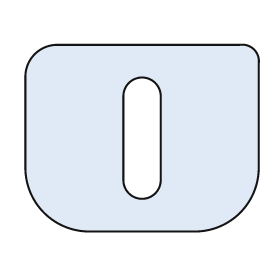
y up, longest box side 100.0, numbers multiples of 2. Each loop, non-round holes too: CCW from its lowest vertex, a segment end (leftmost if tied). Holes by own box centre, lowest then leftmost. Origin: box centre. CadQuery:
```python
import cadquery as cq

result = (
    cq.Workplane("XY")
    .moveTo(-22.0, -40.0)
    .lineTo(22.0, -40.0)
    .threePointArc((42.0, -32.0), (50.0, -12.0))
    .lineTo(50.0, 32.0)
    .threePointArc((48.0, 38.0), (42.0, 40.0))
    .lineTo(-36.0, 40.0)
    .threePointArc((-46.0, 36.0), (-50.0, 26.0))
    .lineTo(-50.0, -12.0)
    .threePointArc((-42.0, -32.0), (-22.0, -40.0))
    .close()
    .moveTo(-8.0, -18.0)
    .threePointArc((0.0, -26.0), (8.0, -18.0))
    .lineTo(8.0, 18.0)
    .threePointArc((0.0, 26.0), (-8.0, 18.0))
    .close()
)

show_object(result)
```